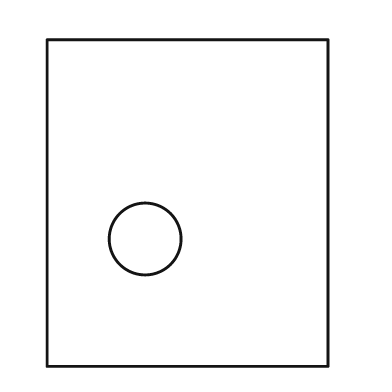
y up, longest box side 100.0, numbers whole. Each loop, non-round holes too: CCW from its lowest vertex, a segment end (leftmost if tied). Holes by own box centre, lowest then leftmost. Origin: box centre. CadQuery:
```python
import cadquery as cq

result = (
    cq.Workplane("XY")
    .moveTo(-43.0, -50.0)
    .lineTo(43.0, -50.0)
    .lineTo(43.0, 50.0)
    .lineTo(-43.0, 50.0)
    .close()
    .moveTo(-13.0, -11.0)
    .circle(11.0)
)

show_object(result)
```